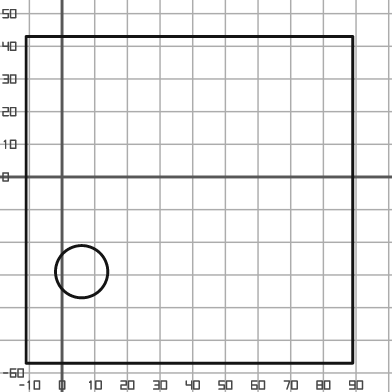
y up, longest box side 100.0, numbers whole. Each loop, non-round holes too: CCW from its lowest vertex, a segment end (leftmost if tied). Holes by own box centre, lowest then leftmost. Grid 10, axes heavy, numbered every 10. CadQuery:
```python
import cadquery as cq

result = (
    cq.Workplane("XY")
    .moveTo(-11.0, -57.0)
    .lineTo(89.0, -57.0)
    .lineTo(89.0, 43.0)
    .lineTo(-11.0, 43.0)
    .close()
    .moveTo(6.0, -29.0)
    .circle(8.0)
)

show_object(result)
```